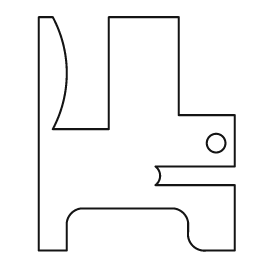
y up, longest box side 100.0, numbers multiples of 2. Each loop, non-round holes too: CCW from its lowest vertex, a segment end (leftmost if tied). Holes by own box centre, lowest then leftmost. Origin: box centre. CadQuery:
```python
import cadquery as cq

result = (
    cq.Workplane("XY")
    .moveTo(-42.0, -50.0)
    .lineTo(-30.0, -50.0)
    .lineTo(-30.0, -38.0)
    .threePointArc((-28.0, -34.0), (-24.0, -32.0))
    .lineTo(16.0, -32.0)
    .threePointArc((20.0, -34.0), (22.0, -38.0))
    .lineTo(22.0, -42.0)
    .threePointArc((24.0, -48.0), (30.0, -50.0))
    .lineTo(42.0, -50.0)
    .lineTo(42.0, -22.0)
    .lineTo(8.0, -22.0)
    .threePointArc((10.0, -18.0), (8.0, -14.0))
    .lineTo(42.0, -14.0)
    .lineTo(42.0, 8.0)
    .lineTo(18.0, 8.0)
    .lineTo(18.0, 50.0)
    .lineTo(-12.0, 50.0)
    .lineTo(-12.0, 2.0)
    .lineTo(-36.0, 2.0)
    .threePointArc((-30.0, 26.0), (-36.0, 50.0))
    .lineTo(-42.0, 50.0)
    .close()
    .moveTo(34.0, -4.0)
    .circle(4.0)
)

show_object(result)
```